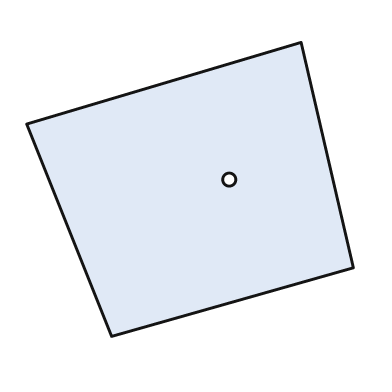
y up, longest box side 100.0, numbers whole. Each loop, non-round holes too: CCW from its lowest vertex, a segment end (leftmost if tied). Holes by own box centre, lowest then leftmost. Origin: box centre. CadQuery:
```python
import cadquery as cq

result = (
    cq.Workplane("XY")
    .moveTo(-24.0, -45.0)
    .lineTo(50.0, -24.0)
    .lineTo(34.0, 45.0)
    .lineTo(-50.0, 20.0)
    .close()
    .moveTo(12.0, 3.0)
    .circle(2.0)
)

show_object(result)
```